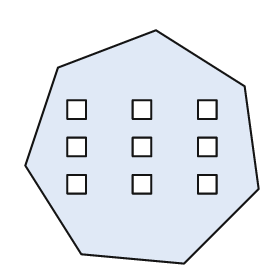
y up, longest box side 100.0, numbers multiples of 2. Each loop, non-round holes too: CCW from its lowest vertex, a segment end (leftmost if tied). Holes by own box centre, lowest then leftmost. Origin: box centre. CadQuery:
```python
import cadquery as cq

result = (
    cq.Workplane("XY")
    .moveTo(18.0, -50.0)
    .lineTo(50.0, -18.0)
    .lineTo(44.0, 26.0)
    .lineTo(6.0, 50.0)
    .lineTo(-36.0, 34.0)
    .lineTo(-50.0, -8.0)
    .lineTo(-26.0, -46.0)
    .close()
    .moveTo(-32.0, -20.0)
    .lineTo(-24.0, -20.0)
    .lineTo(-24.0, -12.0)
    .lineTo(-32.0, -12.0)
    .close()
    .moveTo(-4.0, -20.0)
    .lineTo(4.0, -20.0)
    .lineTo(4.0, -12.0)
    .lineTo(-4.0, -12.0)
    .close()
    .moveTo(24.0, -20.0)
    .lineTo(32.0, -20.0)
    .lineTo(32.0, -12.0)
    .lineTo(24.0, -12.0)
    .close()
    .moveTo(-32.0, -4.0)
    .lineTo(-24.0, -4.0)
    .lineTo(-24.0, 4.0)
    .lineTo(-32.0, 4.0)
    .close()
    .moveTo(-4.0, -4.0)
    .lineTo(4.0, -4.0)
    .lineTo(4.0, 4.0)
    .lineTo(-4.0, 4.0)
    .close()
    .moveTo(24.0, -4.0)
    .lineTo(32.0, -4.0)
    .lineTo(32.0, 4.0)
    .lineTo(24.0, 4.0)
    .close()
    .moveTo(-32.0, 12.0)
    .lineTo(-24.0, 12.0)
    .lineTo(-24.0, 20.0)
    .lineTo(-32.0, 20.0)
    .close()
    .moveTo(-4.0, 12.0)
    .lineTo(4.0, 12.0)
    .lineTo(4.0, 20.0)
    .lineTo(-4.0, 20.0)
    .close()
    .moveTo(24.0, 12.0)
    .lineTo(32.0, 12.0)
    .lineTo(32.0, 20.0)
    .lineTo(24.0, 20.0)
    .close()
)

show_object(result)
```